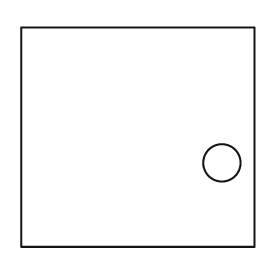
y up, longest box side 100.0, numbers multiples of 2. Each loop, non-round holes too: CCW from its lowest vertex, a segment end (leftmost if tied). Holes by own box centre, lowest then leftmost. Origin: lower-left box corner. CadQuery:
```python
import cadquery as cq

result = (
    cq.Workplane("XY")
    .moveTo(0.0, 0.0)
    .lineTo(100.0, 0.0)
    .lineTo(100.0, 94.0)
    .lineTo(0.0, 94.0)
    .close()
    .moveTo(86.0, 36.0)
    .circle(8.0)
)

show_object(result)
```